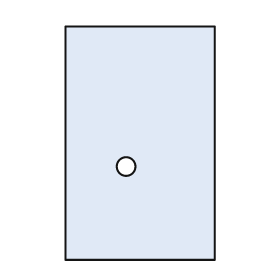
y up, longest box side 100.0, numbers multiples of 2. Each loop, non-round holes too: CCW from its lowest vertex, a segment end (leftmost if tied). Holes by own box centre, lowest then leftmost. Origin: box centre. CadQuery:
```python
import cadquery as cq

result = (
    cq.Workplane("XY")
    .moveTo(-32.0, -50.0)
    .lineTo(32.0, -50.0)
    .lineTo(32.0, 50.0)
    .lineTo(-32.0, 50.0)
    .close()
    .moveTo(-6.0, -10.0)
    .circle(4.0)
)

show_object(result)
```